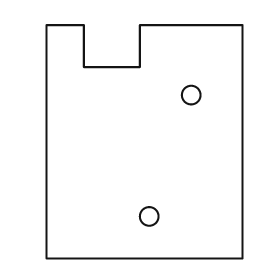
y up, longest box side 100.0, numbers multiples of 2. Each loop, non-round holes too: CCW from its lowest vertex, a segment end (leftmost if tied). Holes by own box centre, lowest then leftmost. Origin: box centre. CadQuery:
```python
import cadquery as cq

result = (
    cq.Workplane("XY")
    .moveTo(-42.0, -50.0)
    .lineTo(42.0, -50.0)
    .lineTo(42.0, 50.0)
    .lineTo(-2.0, 50.0)
    .lineTo(-2.0, 32.0)
    .lineTo(-26.0, 32.0)
    .lineTo(-26.0, 50.0)
    .lineTo(-42.0, 50.0)
    .close()
    .moveTo(2.0, -32.0)
    .circle(4.0)
    .moveTo(20.0, 20.0)
    .circle(4.0)
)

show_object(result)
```